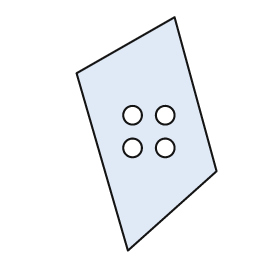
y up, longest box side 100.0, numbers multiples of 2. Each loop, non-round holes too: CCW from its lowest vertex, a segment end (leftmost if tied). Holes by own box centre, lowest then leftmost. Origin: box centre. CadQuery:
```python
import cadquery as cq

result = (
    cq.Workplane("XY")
    .moveTo(-8.0, -50.0)
    .lineTo(30.0, -16.0)
    .lineTo(12.0, 50.0)
    .lineTo(-30.0, 26.0)
    .close()
    .moveTo(-6.0, -6.0)
    .circle(4.0)
    .moveTo(8.0, -6.0)
    .circle(4.0)
    .moveTo(-6.0, 8.0)
    .circle(4.0)
    .moveTo(8.0, 8.0)
    .circle(4.0)
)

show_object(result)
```